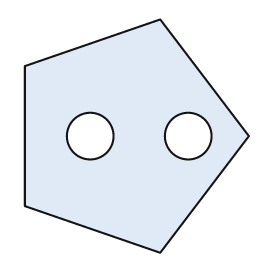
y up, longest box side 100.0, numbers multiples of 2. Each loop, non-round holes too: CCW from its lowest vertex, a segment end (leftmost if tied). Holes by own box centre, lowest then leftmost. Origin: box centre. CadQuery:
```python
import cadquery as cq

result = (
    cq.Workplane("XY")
    .moveTo(10.0, -50.0)
    .lineTo(48.0, 0.0)
    .lineTo(10.0, 50.0)
    .lineTo(-48.0, 30.0)
    .lineTo(-48.0, -30.0)
    .close()
    .moveTo(-20.0, 0.0)
    .circle(10.0)
    .moveTo(22.0, 0.0)
    .circle(10.0)
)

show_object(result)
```